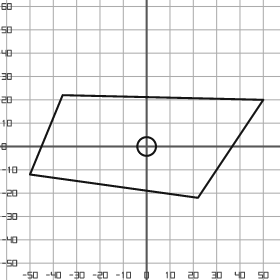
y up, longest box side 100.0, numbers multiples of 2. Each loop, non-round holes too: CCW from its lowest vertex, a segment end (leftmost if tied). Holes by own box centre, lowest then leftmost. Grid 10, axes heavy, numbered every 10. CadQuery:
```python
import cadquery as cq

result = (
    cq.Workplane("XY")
    .moveTo(22.0, -22.0)
    .lineTo(50.0, 20.0)
    .lineTo(-36.0, 22.0)
    .lineTo(-50.0, -12.0)
    .close()
    .moveTo(0.0, 0.0)
    .circle(4.0)
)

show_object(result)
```